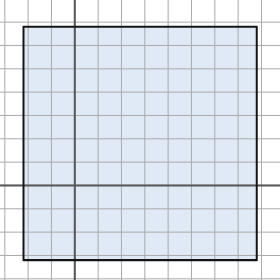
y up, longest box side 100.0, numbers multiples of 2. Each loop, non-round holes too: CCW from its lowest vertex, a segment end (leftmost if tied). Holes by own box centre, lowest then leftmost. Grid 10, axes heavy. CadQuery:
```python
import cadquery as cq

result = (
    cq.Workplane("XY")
    .moveTo(-22.0, -32.0)
    .lineTo(78.0, -32.0)
    .lineTo(78.0, 68.0)
    .lineTo(-22.0, 68.0)
    .close()
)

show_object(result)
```